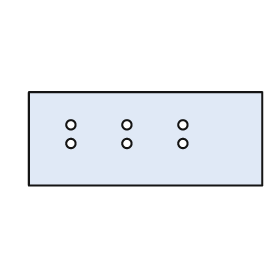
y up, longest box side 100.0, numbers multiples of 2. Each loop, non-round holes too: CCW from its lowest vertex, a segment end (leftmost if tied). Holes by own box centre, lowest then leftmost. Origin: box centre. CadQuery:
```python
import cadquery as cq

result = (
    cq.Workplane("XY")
    .moveTo(-50.0, -20.0)
    .lineTo(50.0, -20.0)
    .lineTo(50.0, 20.0)
    .lineTo(-50.0, 20.0)
    .close()
    .moveTo(-32.0, -2.0)
    .circle(2.0)
    .moveTo(-8.0, -2.0)
    .circle(2.0)
    .moveTo(16.0, -2.0)
    .circle(2.0)
    .moveTo(-32.0, 6.0)
    .circle(2.0)
    .moveTo(-8.0, 6.0)
    .circle(2.0)
    .moveTo(16.0, 6.0)
    .circle(2.0)
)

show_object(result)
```